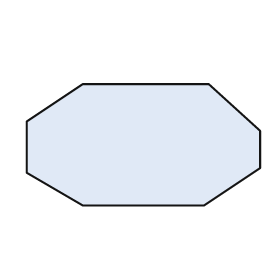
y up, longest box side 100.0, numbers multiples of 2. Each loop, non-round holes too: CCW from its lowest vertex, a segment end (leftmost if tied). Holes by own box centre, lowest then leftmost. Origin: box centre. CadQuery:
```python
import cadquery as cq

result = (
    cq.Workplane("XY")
    .moveTo(-26.0, -26.0)
    .lineTo(26.0, -26.0)
    .lineTo(50.0, -10.0)
    .lineTo(50.0, 6.0)
    .lineTo(28.0, 26.0)
    .lineTo(-26.0, 26.0)
    .lineTo(-50.0, 10.0)
    .lineTo(-50.0, -12.0)
    .close()
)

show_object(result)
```